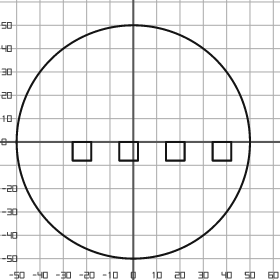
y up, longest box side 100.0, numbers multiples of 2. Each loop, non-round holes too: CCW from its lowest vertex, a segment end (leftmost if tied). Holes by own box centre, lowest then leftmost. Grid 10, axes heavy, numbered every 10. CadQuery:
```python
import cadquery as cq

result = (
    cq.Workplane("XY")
    .moveTo(0.0, 0.0)
    .circle(50.0)
    .moveTo(-26.0, -8.0)
    .lineTo(-18.0, -8.0)
    .lineTo(-18.0, 0.0)
    .lineTo(-26.0, 0.0)
    .close()
    .moveTo(-6.0, -8.0)
    .lineTo(2.0, -8.0)
    .lineTo(2.0, 0.0)
    .lineTo(-6.0, 0.0)
    .close()
    .moveTo(14.0, -8.0)
    .lineTo(22.0, -8.0)
    .lineTo(22.0, 0.0)
    .lineTo(14.0, 0.0)
    .close()
    .moveTo(34.0, -8.0)
    .lineTo(42.0, -8.0)
    .lineTo(42.0, 0.0)
    .lineTo(34.0, 0.0)
    .close()
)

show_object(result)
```